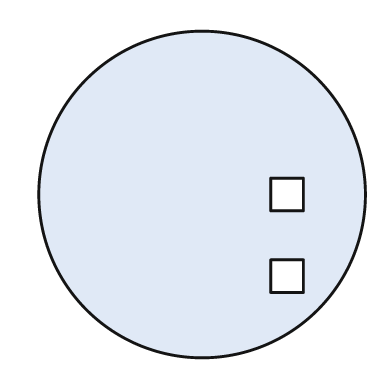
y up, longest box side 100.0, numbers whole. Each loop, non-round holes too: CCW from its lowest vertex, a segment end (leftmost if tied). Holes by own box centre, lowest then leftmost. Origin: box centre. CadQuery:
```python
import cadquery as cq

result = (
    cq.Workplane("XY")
    .moveTo(0.0, 0.0)
    .circle(50.0)
    .moveTo(21.0, -30.0)
    .lineTo(31.0, -30.0)
    .lineTo(31.0, -20.0)
    .lineTo(21.0, -20.0)
    .close()
    .moveTo(21.0, -5.0)
    .lineTo(31.0, -5.0)
    .lineTo(31.0, 5.0)
    .lineTo(21.0, 5.0)
    .close()
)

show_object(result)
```